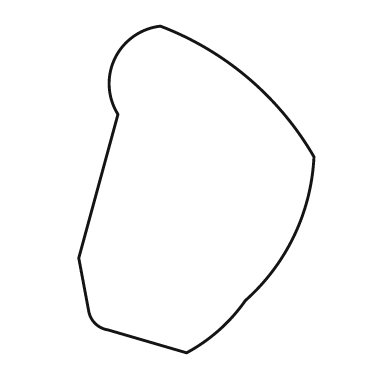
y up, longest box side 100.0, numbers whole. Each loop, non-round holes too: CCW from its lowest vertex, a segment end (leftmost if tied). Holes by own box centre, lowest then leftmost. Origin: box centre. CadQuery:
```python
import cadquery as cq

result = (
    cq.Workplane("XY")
    .moveTo(-3.0, -50.0)
    .threePointArc((7.0, -43.0), (15.0, -34.0))
    .threePointArc((30.0, -14.0), (36.0, 10.0))
    .threePointArc((16.0, 34.0), (-11.0, 50.0))
    .threePointArc((-25.0, 40.0), (-24.0, 23.0))
    .lineTo(-36.0, -21.0)
    .lineTo(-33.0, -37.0)
    .threePointArc((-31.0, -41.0), (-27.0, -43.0))
    .close()
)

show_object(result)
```